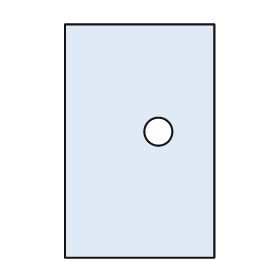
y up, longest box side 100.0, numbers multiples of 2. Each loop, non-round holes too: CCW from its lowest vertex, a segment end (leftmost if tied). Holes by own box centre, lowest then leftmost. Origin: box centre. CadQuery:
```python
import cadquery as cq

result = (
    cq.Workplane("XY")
    .moveTo(-32.0, -50.0)
    .lineTo(32.0, -50.0)
    .lineTo(32.0, 50.0)
    .lineTo(-32.0, 50.0)
    .close()
    .moveTo(8.0, 4.0)
    .circle(6.0)
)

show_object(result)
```